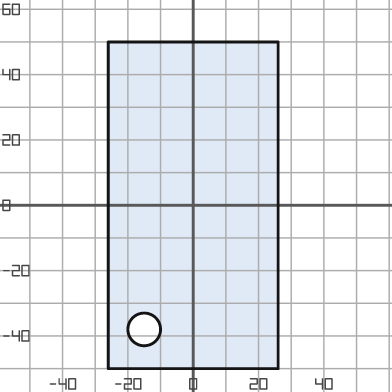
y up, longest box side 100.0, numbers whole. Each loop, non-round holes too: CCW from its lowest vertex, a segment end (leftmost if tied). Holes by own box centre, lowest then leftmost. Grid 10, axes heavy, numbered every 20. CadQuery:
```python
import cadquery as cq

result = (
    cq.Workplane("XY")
    .moveTo(-26.0, -50.0)
    .lineTo(26.0, -50.0)
    .lineTo(26.0, 50.0)
    .lineTo(-26.0, 50.0)
    .close()
    .moveTo(-15.0, -38.0)
    .circle(5.0)
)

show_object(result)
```